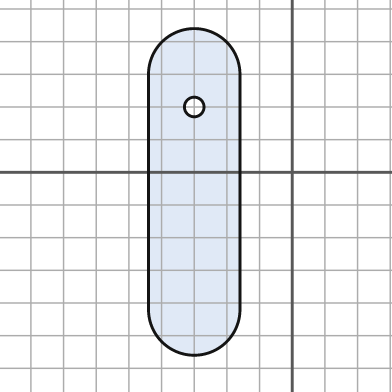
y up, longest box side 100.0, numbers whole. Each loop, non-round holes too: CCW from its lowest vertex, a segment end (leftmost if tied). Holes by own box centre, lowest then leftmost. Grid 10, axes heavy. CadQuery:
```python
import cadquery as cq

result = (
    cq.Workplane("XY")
    .moveTo(-44.0, -42.0)
    .threePointArc((-30.0, -56.0), (-16.0, -42.0))
    .lineTo(-16.0, 30.0)
    .threePointArc((-30.0, 44.0), (-44.0, 30.0))
    .close()
    .moveTo(-30.0, 20.0)
    .circle(3.0)
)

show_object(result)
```